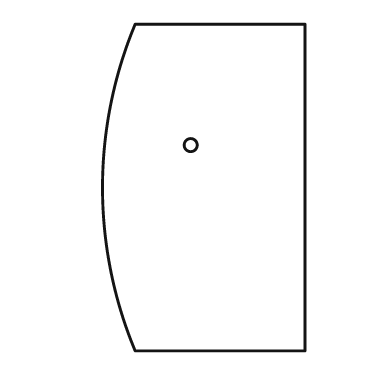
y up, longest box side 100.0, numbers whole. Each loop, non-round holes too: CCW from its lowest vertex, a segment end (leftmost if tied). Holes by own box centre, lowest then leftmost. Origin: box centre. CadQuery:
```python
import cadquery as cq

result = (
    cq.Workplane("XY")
    .moveTo(-21.0, -50.0)
    .lineTo(31.0, -50.0)
    .lineTo(31.0, 50.0)
    .lineTo(-21.0, 50.0)
    .threePointArc((-31.0, 0.0), (-21.0, -50.0))
    .close()
    .moveTo(-4.0, 13.0)
    .circle(2.0)
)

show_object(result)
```